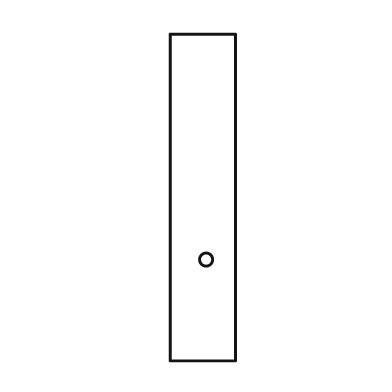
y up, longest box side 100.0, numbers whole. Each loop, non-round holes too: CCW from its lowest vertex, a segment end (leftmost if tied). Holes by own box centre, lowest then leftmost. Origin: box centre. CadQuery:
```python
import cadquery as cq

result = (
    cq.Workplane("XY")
    .moveTo(-10.0, -50.0)
    .lineTo(10.0, -50.0)
    .lineTo(10.0, 50.0)
    .lineTo(-10.0, 50.0)
    .close()
    .moveTo(1.0, -19.0)
    .circle(2.0)
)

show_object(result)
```